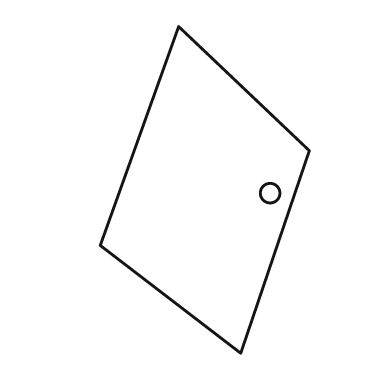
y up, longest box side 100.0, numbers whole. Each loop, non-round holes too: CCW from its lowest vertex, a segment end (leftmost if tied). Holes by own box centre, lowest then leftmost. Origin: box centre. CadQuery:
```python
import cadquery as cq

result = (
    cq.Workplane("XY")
    .moveTo(11.0, -50.0)
    .lineTo(32.0, 12.0)
    .lineTo(-8.0, 50.0)
    .lineTo(-32.0, -17.0)
    .close()
    .moveTo(20.0, -1.0)
    .circle(3.0)
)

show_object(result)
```